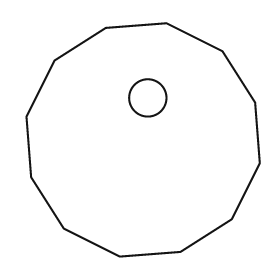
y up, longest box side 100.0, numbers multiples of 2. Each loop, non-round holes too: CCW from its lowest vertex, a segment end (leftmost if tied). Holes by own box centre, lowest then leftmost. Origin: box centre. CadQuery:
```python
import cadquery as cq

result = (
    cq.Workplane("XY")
    .moveTo(-10.0, -50.0)
    .lineTo(16.0, -48.0)
    .lineTo(38.0, -34.0)
    .lineTo(50.0, -10.0)
    .lineTo(48.0, 16.0)
    .lineTo(34.0, 38.0)
    .lineTo(10.0, 50.0)
    .lineTo(-16.0, 48.0)
    .lineTo(-38.0, 34.0)
    .lineTo(-50.0, 10.0)
    .lineTo(-48.0, -16.0)
    .lineTo(-34.0, -38.0)
    .close()
    .moveTo(2.0, 18.0)
    .circle(8.0)
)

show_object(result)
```